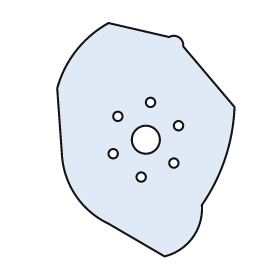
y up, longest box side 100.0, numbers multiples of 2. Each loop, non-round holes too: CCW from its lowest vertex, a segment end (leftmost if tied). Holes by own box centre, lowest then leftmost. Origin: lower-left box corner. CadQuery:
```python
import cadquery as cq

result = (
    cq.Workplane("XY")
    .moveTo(46.0, 0.0)
    .threePointArc((58.0, 8.0), (62.0, 22.0))
    .threePointArc((72.0, 42.0), (76.0, 64.0))
    .lineTo(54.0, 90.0)
    .threePointArc((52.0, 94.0), (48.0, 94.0))
    .lineTo(22.0, 100.0)
    .threePointArc((8.0, 88.0), (0.0, 72.0))
    .lineTo(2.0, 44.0)
    .threePointArc((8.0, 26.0), (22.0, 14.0))
    .close()
    .moveTo(36.0, 34.0)
    .circle(2.0)
    .moveTo(50.0, 40.0)
    .circle(2.0)
    .moveTo(24.0, 44.0)
    .circle(2.0)
    .moveTo(38.0, 50.0)
    .circle(6.0)
    .moveTo(52.0, 56.0)
    .circle(2.0)
    .moveTo(26.0, 60.0)
    .circle(2.0)
    .moveTo(40.0, 66.0)
    .circle(2.0)
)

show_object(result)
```